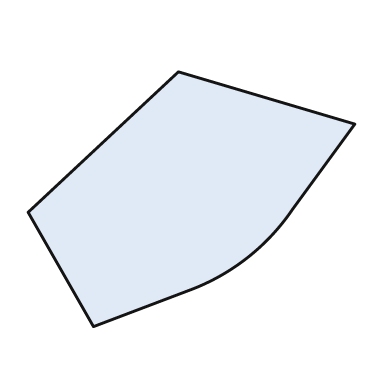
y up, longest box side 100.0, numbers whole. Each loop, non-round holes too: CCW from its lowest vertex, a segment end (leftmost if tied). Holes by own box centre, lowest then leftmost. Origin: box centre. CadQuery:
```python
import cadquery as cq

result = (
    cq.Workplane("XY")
    .moveTo(-30.0, -39.0)
    .lineTo(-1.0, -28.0)
    .threePointArc((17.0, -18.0), (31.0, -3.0))
    .lineTo(50.0, 23.0)
    .lineTo(-4.0, 39.0)
    .lineTo(-50.0, -4.0)
    .close()
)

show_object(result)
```